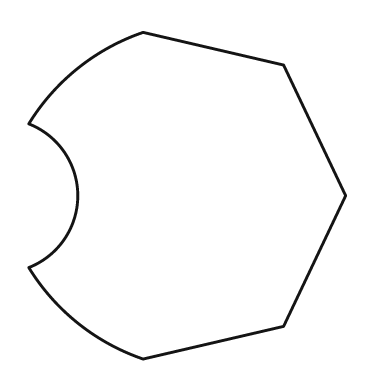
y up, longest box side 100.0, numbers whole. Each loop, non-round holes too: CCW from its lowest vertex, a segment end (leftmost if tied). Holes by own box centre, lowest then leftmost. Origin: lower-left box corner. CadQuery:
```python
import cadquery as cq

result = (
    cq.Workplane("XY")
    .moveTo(35.0, 0.0)
    .lineTo(78.0, 10.0)
    .lineTo(97.0, 50.0)
    .lineTo(78.0, 90.0)
    .lineTo(35.0, 100.0)
    .threePointArc((15.0, 89.0), (0.0, 72.0))
    .threePointArc((15.0, 50.0), (0.0, 28.0))
    .threePointArc((15.0, 11.0), (35.0, 0.0))
    .close()
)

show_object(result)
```